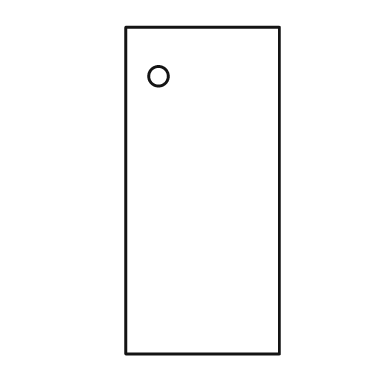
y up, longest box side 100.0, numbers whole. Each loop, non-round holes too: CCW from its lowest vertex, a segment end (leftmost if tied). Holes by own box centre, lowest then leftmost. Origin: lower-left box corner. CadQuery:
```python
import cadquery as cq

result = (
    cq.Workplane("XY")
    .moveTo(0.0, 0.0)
    .lineTo(47.0, 0.0)
    .lineTo(47.0, 100.0)
    .lineTo(0.0, 100.0)
    .close()
    .moveTo(10.0, 85.0)
    .circle(3.0)
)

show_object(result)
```